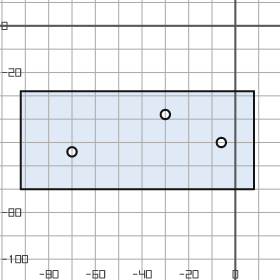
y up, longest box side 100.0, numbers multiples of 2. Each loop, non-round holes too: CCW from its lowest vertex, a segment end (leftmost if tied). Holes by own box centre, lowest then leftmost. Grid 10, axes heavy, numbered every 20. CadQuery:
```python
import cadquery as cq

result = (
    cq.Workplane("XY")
    .moveTo(-92.0, -70.0)
    .lineTo(8.0, -70.0)
    .lineTo(8.0, -28.0)
    .lineTo(-92.0, -28.0)
    .close()
    .moveTo(-70.0, -54.0)
    .circle(2.0)
    .moveTo(-6.0, -50.0)
    .circle(2.0)
    .moveTo(-30.0, -38.0)
    .circle(2.0)
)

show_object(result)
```